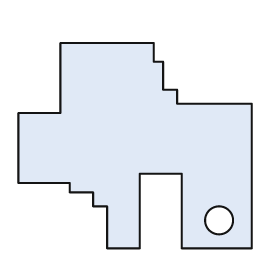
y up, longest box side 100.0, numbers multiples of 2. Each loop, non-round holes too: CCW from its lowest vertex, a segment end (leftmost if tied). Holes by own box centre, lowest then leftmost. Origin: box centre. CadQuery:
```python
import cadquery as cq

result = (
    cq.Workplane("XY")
    .moveTo(-12.0, -44.0)
    .lineTo(2.0, -44.0)
    .lineTo(2.0, -12.0)
    .lineTo(20.0, -12.0)
    .lineTo(20.0, -44.0)
    .lineTo(50.0, -44.0)
    .lineTo(50.0, 18.0)
    .lineTo(18.0, 18.0)
    .lineTo(18.0, 24.0)
    .lineTo(12.0, 24.0)
    .lineTo(12.0, 36.0)
    .lineTo(8.0, 36.0)
    .lineTo(8.0, 44.0)
    .lineTo(-32.0, 44.0)
    .lineTo(-32.0, 14.0)
    .lineTo(-50.0, 14.0)
    .lineTo(-50.0, -16.0)
    .lineTo(-28.0, -16.0)
    .lineTo(-28.0, -20.0)
    .lineTo(-18.0, -20.0)
    .lineTo(-18.0, -26.0)
    .lineTo(-12.0, -26.0)
    .close()
    .moveTo(36.0, -32.0)
    .circle(6.0)
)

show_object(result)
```